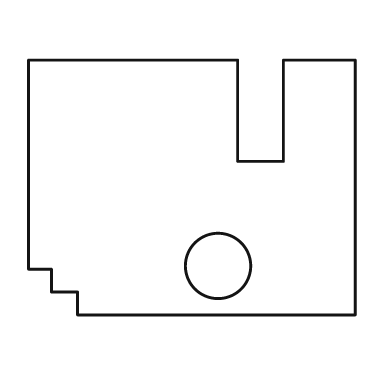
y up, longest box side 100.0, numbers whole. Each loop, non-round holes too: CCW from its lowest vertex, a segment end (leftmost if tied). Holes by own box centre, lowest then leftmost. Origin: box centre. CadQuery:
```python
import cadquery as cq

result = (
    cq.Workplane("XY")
    .moveTo(-35.0, -39.0)
    .lineTo(50.0, -39.0)
    .lineTo(50.0, 39.0)
    .lineTo(28.0, 39.0)
    .lineTo(28.0, 8.0)
    .lineTo(14.0, 8.0)
    .lineTo(14.0, 39.0)
    .lineTo(-50.0, 39.0)
    .lineTo(-50.0, -25.0)
    .lineTo(-43.0, -25.0)
    .lineTo(-43.0, -32.0)
    .lineTo(-35.0, -32.0)
    .close()
    .moveTo(8.0, -24.0)
    .circle(10.0)
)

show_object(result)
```